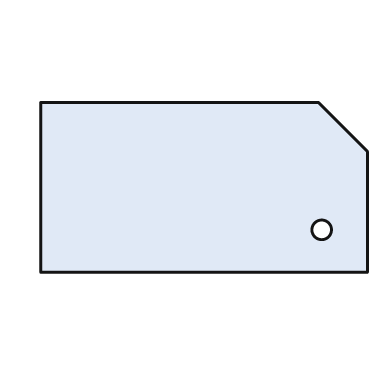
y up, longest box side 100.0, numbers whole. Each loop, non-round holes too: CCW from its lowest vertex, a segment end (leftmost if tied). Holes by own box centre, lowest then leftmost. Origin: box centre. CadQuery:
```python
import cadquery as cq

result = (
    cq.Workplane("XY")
    .moveTo(-50.0, -26.0)
    .lineTo(50.0, -26.0)
    .lineTo(50.0, 11.0)
    .lineTo(35.0, 26.0)
    .lineTo(-50.0, 26.0)
    .close()
    .moveTo(36.0, -13.0)
    .circle(3.0)
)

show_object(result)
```